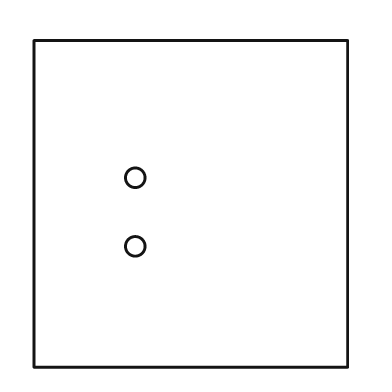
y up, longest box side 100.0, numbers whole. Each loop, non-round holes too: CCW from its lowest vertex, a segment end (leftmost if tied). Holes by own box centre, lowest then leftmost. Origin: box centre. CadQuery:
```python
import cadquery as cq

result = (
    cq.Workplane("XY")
    .moveTo(-48.0, -50.0)
    .lineTo(48.0, -50.0)
    .lineTo(48.0, 50.0)
    .lineTo(-48.0, 50.0)
    .close()
    .moveTo(-17.0, -13.0)
    .circle(3.0)
    .moveTo(-17.0, 8.0)
    .circle(3.0)
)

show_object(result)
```